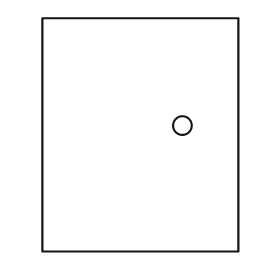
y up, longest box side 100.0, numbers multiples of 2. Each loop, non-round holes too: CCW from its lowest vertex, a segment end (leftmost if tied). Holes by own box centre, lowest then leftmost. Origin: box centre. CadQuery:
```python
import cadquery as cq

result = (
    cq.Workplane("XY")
    .moveTo(-42.0, -50.0)
    .lineTo(42.0, -50.0)
    .lineTo(42.0, 50.0)
    .lineTo(-42.0, 50.0)
    .close()
    .moveTo(18.0, 4.0)
    .circle(4.0)
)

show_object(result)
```